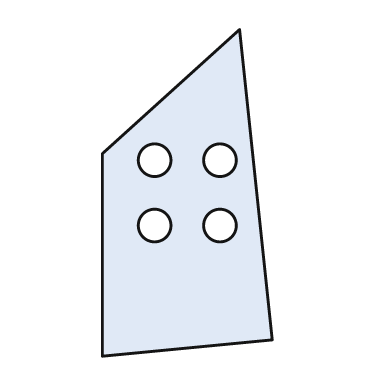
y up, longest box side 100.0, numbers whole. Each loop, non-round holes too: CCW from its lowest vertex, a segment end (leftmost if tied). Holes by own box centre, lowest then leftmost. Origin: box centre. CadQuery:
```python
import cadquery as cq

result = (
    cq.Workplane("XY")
    .moveTo(-26.0, -50.0)
    .lineTo(26.0, -45.0)
    .lineTo(16.0, 50.0)
    .lineTo(-26.0, 12.0)
    .close()
    .moveTo(-10.0, -10.0)
    .circle(5.0)
    .moveTo(10.0, -10.0)
    .circle(5.0)
    .moveTo(-10.0, 10.0)
    .circle(5.0)
    .moveTo(10.0, 10.0)
    .circle(5.0)
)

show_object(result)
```